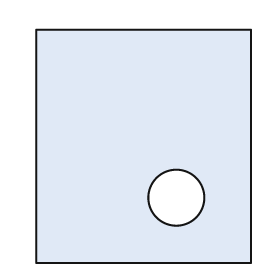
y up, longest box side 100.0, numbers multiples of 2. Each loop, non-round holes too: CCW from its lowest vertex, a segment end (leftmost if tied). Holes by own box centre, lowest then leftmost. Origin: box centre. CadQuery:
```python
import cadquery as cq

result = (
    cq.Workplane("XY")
    .moveTo(-46.0, -50.0)
    .lineTo(46.0, -50.0)
    .lineTo(46.0, 50.0)
    .lineTo(-46.0, 50.0)
    .close()
    .moveTo(14.0, -22.0)
    .circle(12.0)
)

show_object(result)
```